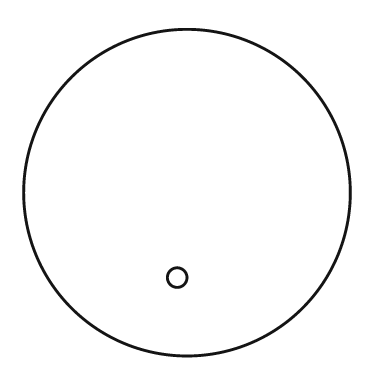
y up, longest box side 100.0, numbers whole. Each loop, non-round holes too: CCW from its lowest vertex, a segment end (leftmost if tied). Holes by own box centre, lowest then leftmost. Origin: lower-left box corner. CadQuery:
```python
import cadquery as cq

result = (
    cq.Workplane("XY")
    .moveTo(50.0, 50.0)
    .circle(50.0)
    .moveTo(47.0, 24.0)
    .circle(3.0)
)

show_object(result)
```